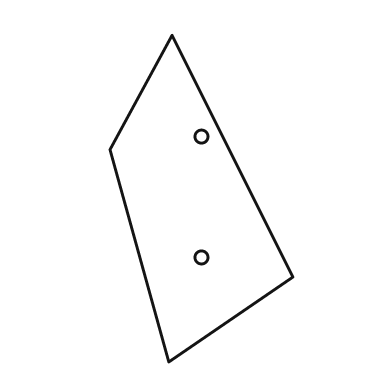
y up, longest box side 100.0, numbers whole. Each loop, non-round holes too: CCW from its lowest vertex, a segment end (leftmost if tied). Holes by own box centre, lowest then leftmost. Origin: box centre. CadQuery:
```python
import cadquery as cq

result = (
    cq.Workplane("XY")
    .moveTo(-10.0, -50.0)
    .lineTo(28.0, -24.0)
    .lineTo(-9.0, 50.0)
    .lineTo(-28.0, 15.0)
    .close()
    .moveTo(0.0, -18.0)
    .circle(2.0)
    .moveTo(0.0, 19.0)
    .circle(2.0)
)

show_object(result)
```